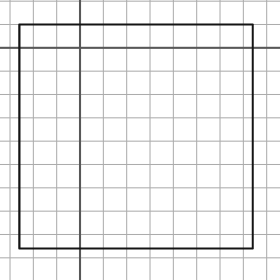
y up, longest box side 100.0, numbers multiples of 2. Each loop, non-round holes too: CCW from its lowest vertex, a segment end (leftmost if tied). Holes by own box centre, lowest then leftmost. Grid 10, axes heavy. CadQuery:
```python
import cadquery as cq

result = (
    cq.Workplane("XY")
    .moveTo(-26.0, -86.0)
    .lineTo(74.0, -86.0)
    .lineTo(74.0, 10.0)
    .lineTo(-26.0, 10.0)
    .close()
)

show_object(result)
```